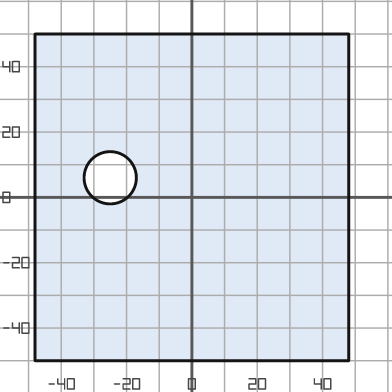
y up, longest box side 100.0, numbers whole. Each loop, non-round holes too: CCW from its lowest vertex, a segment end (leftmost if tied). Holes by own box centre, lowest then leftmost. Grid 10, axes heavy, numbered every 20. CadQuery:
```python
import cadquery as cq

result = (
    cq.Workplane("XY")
    .moveTo(-48.0, -50.0)
    .lineTo(48.0, -50.0)
    .lineTo(48.0, 50.0)
    .lineTo(-48.0, 50.0)
    .close()
    .moveTo(-25.0, 6.0)
    .circle(8.0)
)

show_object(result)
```